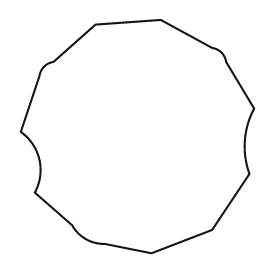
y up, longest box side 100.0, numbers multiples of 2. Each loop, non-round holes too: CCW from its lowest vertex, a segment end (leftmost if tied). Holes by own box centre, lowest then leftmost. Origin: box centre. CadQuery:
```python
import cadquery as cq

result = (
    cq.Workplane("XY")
    .moveTo(6.0, -50.0)
    .lineTo(32.0, -40.0)
    .lineTo(48.0, -16.0)
    .threePointArc((46.0, -2.0), (50.0, 12.0))
    .lineTo(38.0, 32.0)
    .threePointArc((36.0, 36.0), (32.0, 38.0))
    .lineTo(10.0, 50.0)
    .lineTo(-18.0, 48.0)
    .lineTo(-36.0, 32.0)
    .threePointArc((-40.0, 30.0), (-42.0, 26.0))
    .lineTo(-50.0, 2.0)
    .threePointArc((-42.0, -10.0), (-44.0, -24.0))
    .lineTo(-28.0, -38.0)
    .threePointArc((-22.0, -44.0), (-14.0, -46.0))
    .close()
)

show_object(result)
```